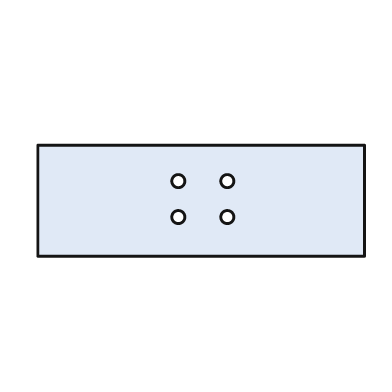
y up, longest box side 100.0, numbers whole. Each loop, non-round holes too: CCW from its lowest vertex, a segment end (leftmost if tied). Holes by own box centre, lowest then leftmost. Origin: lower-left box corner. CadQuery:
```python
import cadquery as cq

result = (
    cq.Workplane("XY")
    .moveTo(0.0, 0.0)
    .lineTo(100.0, 0.0)
    .lineTo(100.0, 34.0)
    .lineTo(0.0, 34.0)
    .close()
    .moveTo(43.0, 12.0)
    .circle(2.0)
    .moveTo(58.0, 12.0)
    .circle(2.0)
    .moveTo(43.0, 23.0)
    .circle(2.0)
    .moveTo(58.0, 23.0)
    .circle(2.0)
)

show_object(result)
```